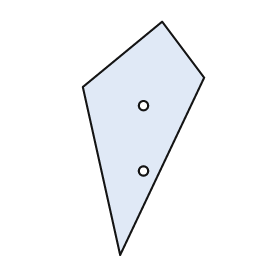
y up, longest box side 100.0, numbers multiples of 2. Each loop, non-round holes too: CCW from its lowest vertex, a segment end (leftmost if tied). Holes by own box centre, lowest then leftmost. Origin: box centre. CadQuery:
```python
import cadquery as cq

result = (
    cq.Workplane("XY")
    .moveTo(-10.0, -50.0)
    .lineTo(26.0, 26.0)
    .lineTo(8.0, 50.0)
    .lineTo(-26.0, 22.0)
    .close()
    .moveTo(0.0, -14.0)
    .circle(2.0)
    .moveTo(0.0, 14.0)
    .circle(2.0)
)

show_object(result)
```